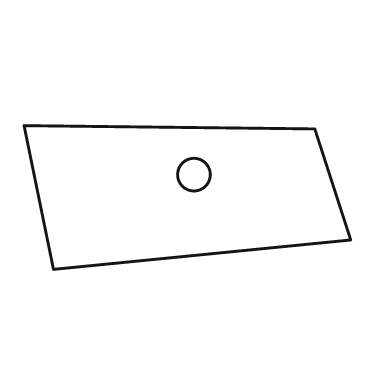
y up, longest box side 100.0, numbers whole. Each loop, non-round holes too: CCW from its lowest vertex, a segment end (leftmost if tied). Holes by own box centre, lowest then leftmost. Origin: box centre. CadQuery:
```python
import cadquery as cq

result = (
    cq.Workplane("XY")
    .moveTo(-41.0, -22.0)
    .lineTo(50.0, -13.0)
    .lineTo(39.0, 21.0)
    .lineTo(-50.0, 22.0)
    .close()
    .moveTo(2.0, 7.0)
    .circle(5.0)
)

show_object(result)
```